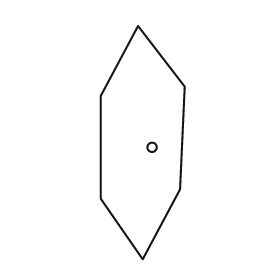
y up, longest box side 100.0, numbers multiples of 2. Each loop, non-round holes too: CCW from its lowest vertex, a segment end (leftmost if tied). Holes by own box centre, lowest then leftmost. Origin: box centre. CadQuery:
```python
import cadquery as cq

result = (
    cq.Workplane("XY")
    .moveTo(0.0, -50.0)
    .lineTo(16.0, -20.0)
    .lineTo(18.0, 24.0)
    .lineTo(-2.0, 50.0)
    .lineTo(-18.0, 20.0)
    .lineTo(-18.0, -24.0)
    .close()
    .moveTo(4.0, -2.0)
    .circle(2.0)
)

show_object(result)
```